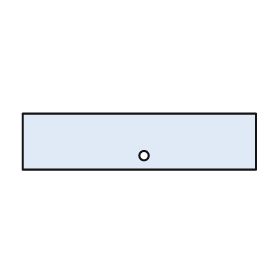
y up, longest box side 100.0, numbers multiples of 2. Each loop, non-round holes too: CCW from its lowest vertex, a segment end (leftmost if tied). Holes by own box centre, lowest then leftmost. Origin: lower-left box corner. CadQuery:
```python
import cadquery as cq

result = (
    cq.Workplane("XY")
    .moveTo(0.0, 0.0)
    .lineTo(100.0, 0.0)
    .lineTo(100.0, 24.0)
    .lineTo(0.0, 24.0)
    .close()
    .moveTo(52.0, 6.0)
    .circle(2.0)
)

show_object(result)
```